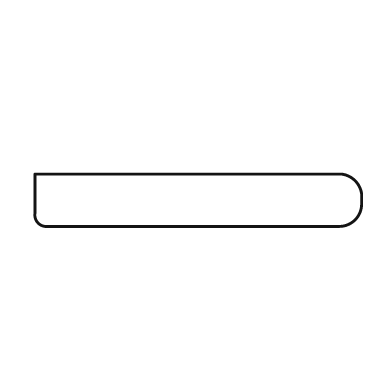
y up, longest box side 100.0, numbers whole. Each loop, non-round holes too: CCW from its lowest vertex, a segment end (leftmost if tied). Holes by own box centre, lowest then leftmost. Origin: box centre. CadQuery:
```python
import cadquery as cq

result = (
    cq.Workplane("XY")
    .moveTo(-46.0, -8.0)
    .lineTo(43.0, -8.0)
    .threePointArc((48.0, -6.0), (50.0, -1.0))
    .lineTo(50.0, 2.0)
    .threePointArc((48.0, 6.0), (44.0, 8.0))
    .lineTo(-50.0, 8.0)
    .lineTo(-50.0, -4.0)
    .threePointArc((-49.0, -7.0), (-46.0, -8.0))
    .close()
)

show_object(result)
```